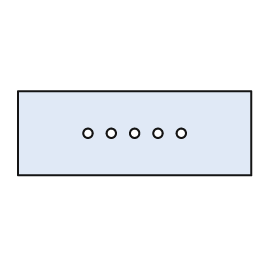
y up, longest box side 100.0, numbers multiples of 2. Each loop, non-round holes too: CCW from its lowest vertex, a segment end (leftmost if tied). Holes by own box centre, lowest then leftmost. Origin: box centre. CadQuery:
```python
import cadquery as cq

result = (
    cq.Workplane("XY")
    .moveTo(-50.0, -18.0)
    .lineTo(50.0, -18.0)
    .lineTo(50.0, 18.0)
    .lineTo(-50.0, 18.0)
    .close()
    .moveTo(-20.0, 0.0)
    .circle(2.0)
    .moveTo(-10.0, 0.0)
    .circle(2.0)
    .moveTo(0.0, 0.0)
    .circle(2.0)
    .moveTo(10.0, 0.0)
    .circle(2.0)
    .moveTo(20.0, 0.0)
    .circle(2.0)
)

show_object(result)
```